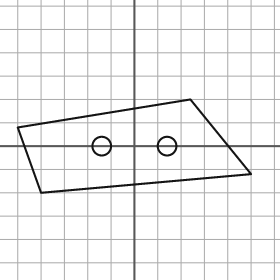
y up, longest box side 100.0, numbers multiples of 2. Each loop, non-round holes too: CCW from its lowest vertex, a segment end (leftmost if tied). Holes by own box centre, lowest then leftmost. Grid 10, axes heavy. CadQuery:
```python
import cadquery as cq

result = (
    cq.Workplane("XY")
    .moveTo(-40.0, -20.0)
    .lineTo(50.0, -12.0)
    .lineTo(24.0, 20.0)
    .lineTo(-50.0, 8.0)
    .close()
    .moveTo(-14.0, 0.0)
    .circle(4.0)
    .moveTo(14.0, 0.0)
    .circle(4.0)
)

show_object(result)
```